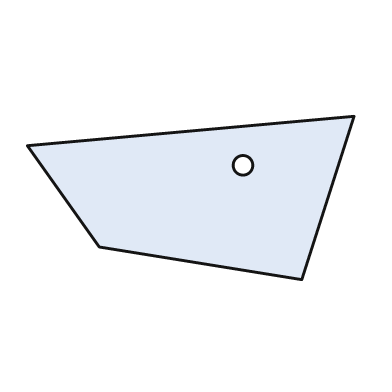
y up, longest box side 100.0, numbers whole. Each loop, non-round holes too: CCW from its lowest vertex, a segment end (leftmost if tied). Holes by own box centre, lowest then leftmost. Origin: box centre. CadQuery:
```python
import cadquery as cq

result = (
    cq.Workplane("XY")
    .moveTo(34.0, -25.0)
    .lineTo(50.0, 25.0)
    .lineTo(-50.0, 16.0)
    .lineTo(-28.0, -15.0)
    .close()
    .moveTo(16.0, 10.0)
    .circle(3.0)
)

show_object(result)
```